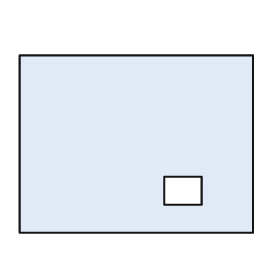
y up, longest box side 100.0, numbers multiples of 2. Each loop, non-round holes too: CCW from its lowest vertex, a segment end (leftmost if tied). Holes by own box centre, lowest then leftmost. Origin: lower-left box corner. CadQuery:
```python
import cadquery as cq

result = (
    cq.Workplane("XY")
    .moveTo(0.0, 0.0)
    .lineTo(100.0, 0.0)
    .lineTo(100.0, 76.0)
    .lineTo(0.0, 76.0)
    .close()
    .moveTo(62.0, 12.0)
    .lineTo(78.0, 12.0)
    .lineTo(78.0, 24.0)
    .lineTo(62.0, 24.0)
    .close()
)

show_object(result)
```